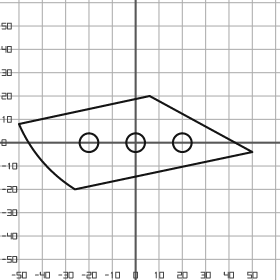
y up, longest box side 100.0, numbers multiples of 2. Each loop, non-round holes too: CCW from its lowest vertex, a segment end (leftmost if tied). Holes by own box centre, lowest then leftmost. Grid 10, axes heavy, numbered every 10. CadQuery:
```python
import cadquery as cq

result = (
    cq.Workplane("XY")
    .moveTo(-26.0, -20.0)
    .lineTo(50.0, -4.0)
    .lineTo(6.0, 20.0)
    .lineTo(-50.0, 8.0)
    .threePointArc((-40.0, -8.0), (-26.0, -20.0))
    .close()
    .moveTo(-20.0, 0.0)
    .circle(4.0)
    .moveTo(0.0, 0.0)
    .circle(4.0)
    .moveTo(20.0, 0.0)
    .circle(4.0)
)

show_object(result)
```